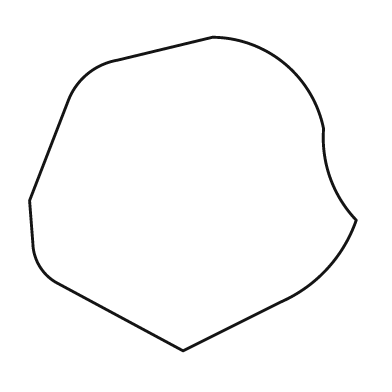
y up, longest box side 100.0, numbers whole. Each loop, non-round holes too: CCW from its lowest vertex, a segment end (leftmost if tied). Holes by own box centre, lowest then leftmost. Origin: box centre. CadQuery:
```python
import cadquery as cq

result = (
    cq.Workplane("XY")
    .moveTo(-3.0, -48.0)
    .lineTo(27.0, -33.0)
    .threePointArc((41.0, -23.0), (50.0, -8.0))
    .threePointArc((42.0, 5.0), (40.0, 20.0))
    .threePointArc((28.0, 40.0), (6.0, 48.0))
    .lineTo(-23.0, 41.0)
    .threePointArc((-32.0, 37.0), (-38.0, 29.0))
    .lineTo(-50.0, -2.0)
    .lineTo(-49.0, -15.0)
    .threePointArc((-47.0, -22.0), (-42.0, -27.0))
    .close()
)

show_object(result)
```